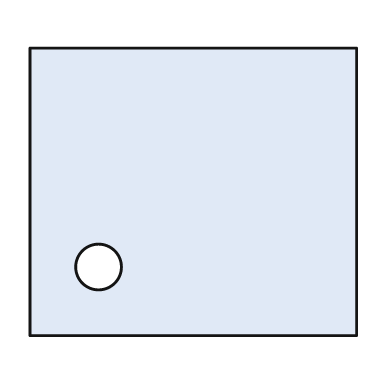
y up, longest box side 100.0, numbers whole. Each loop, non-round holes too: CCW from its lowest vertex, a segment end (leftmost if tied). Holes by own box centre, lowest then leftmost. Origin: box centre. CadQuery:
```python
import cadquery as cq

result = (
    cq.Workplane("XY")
    .moveTo(-50.0, -44.0)
    .lineTo(50.0, -44.0)
    .lineTo(50.0, 44.0)
    .lineTo(-50.0, 44.0)
    .close()
    .moveTo(-29.0, -23.0)
    .circle(7.0)
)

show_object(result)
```